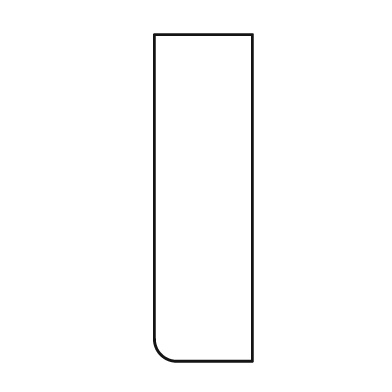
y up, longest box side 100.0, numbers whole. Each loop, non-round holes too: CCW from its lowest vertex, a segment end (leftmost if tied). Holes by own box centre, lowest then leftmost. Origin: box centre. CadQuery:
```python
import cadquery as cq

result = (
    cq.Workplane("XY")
    .moveTo(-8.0, -50.0)
    .lineTo(15.0, -50.0)
    .lineTo(15.0, 50.0)
    .lineTo(-15.0, 50.0)
    .lineTo(-15.0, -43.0)
    .threePointArc((-13.0, -48.0), (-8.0, -50.0))
    .close()
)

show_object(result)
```